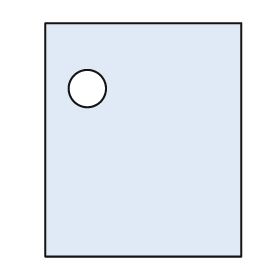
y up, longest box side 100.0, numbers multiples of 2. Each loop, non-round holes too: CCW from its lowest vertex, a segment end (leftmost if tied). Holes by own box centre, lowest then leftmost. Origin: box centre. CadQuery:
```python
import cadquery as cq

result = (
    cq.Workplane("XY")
    .moveTo(-42.0, -50.0)
    .lineTo(42.0, -50.0)
    .lineTo(42.0, 50.0)
    .lineTo(-42.0, 50.0)
    .close()
    .moveTo(-24.0, 22.0)
    .circle(8.0)
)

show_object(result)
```